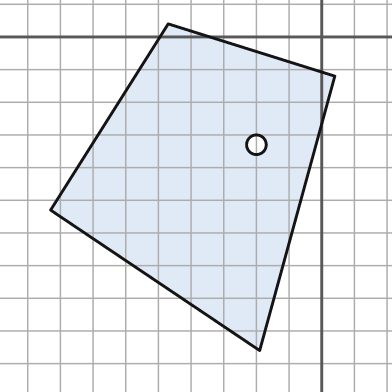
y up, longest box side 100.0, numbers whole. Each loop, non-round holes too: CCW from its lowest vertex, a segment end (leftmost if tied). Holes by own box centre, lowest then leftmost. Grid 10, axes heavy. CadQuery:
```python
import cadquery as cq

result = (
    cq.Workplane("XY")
    .moveTo(-19.0, -96.0)
    .lineTo(4.0, -12.0)
    .lineTo(-47.0, 4.0)
    .lineTo(-83.0, -53.0)
    .close()
    .moveTo(-20.0, -33.0)
    .circle(3.0)
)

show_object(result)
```